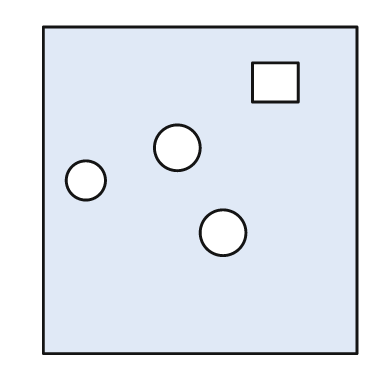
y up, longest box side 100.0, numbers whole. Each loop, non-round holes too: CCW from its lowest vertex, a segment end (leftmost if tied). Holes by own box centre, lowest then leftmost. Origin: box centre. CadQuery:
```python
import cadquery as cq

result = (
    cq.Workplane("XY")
    .moveTo(-48.0, -50.0)
    .lineTo(48.0, -50.0)
    .lineTo(48.0, 50.0)
    .lineTo(-48.0, 50.0)
    .close()
    .moveTo(7.0, -13.0)
    .circle(7.0)
    .moveTo(-35.0, 3.0)
    .circle(6.0)
    .moveTo(-7.0, 13.0)
    .circle(7.0)
    .moveTo(16.0, 27.0)
    .lineTo(30.0, 27.0)
    .lineTo(30.0, 39.0)
    .lineTo(16.0, 39.0)
    .close()
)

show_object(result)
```